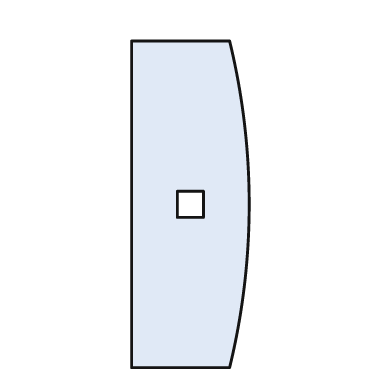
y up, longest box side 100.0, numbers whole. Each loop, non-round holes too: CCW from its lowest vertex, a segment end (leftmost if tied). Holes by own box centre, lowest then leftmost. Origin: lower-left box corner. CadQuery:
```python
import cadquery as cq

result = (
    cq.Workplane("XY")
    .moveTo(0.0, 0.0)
    .lineTo(30.0, 0.0)
    .threePointArc((36.0, 50.0), (30.0, 100.0))
    .lineTo(0.0, 100.0)
    .close()
    .moveTo(14.0, 46.0)
    .lineTo(22.0, 46.0)
    .lineTo(22.0, 54.0)
    .lineTo(14.0, 54.0)
    .close()
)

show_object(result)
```